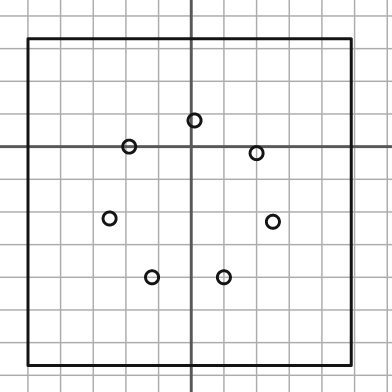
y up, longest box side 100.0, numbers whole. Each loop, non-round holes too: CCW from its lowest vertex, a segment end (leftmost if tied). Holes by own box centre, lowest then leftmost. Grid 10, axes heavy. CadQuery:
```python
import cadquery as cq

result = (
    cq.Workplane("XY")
    .moveTo(-50.0, -67.0)
    .lineTo(49.0, -67.0)
    .lineTo(49.0, 33.0)
    .lineTo(-50.0, 33.0)
    .close()
    .moveTo(-12.0, -40.0)
    .circle(2.0)
    .moveTo(10.0, -40.0)
    .circle(2.0)
    .moveTo(25.0, -23.0)
    .circle(2.0)
    .moveTo(-25.0, -22.0)
    .circle(2.0)
    .moveTo(20.0, -2.0)
    .circle(2.0)
    .moveTo(-19.0, 0.0)
    .circle(2.0)
    .moveTo(1.0, 8.0)
    .circle(2.0)
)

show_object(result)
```